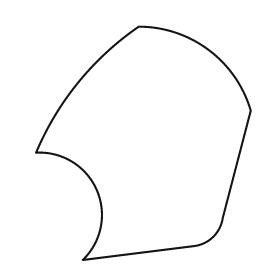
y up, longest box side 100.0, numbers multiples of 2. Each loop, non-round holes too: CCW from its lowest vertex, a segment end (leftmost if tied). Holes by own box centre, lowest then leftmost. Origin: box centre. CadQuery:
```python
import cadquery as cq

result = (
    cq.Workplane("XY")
    .moveTo(-26.0, -50.0)
    .lineTo(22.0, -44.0)
    .threePointArc((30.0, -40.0), (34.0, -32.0))
    .lineTo(46.0, 14.0)
    .threePointArc((28.0, 40.0), (-2.0, 50.0))
    .threePointArc((-28.0, 26.0), (-46.0, -4.0))
    .threePointArc((-20.0, -20.0), (-26.0, -50.0))
    .close()
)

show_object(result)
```